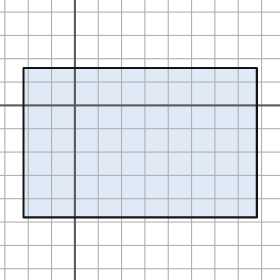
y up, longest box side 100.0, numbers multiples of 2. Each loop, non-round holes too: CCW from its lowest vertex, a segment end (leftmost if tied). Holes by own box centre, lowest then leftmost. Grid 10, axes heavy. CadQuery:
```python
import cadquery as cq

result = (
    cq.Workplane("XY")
    .moveTo(-22.0, -48.0)
    .lineTo(78.0, -48.0)
    .lineTo(78.0, 16.0)
    .lineTo(-22.0, 16.0)
    .close()
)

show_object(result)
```